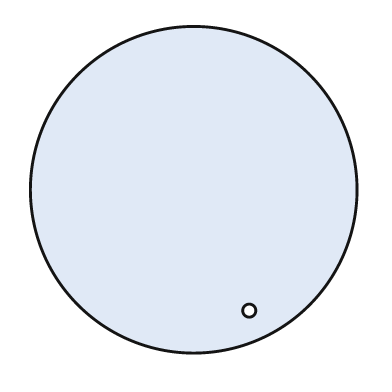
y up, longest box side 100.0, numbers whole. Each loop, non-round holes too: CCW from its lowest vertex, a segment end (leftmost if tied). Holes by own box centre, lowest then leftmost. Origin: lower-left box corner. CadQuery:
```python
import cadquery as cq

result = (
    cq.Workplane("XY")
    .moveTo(50.0, 50.0)
    .circle(50.0)
    .moveTo(67.0, 13.0)
    .circle(2.0)
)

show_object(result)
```